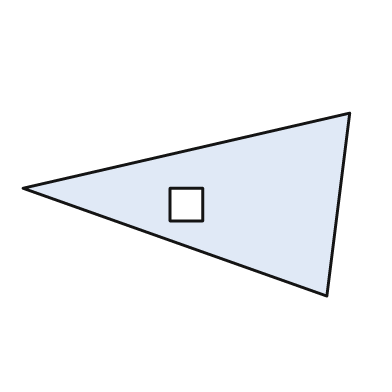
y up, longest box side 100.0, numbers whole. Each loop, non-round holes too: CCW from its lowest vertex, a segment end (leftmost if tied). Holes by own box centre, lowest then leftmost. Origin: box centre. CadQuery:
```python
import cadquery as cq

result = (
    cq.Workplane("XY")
    .moveTo(43.0, -28.0)
    .lineTo(50.0, 28.0)
    .lineTo(-50.0, 5.0)
    .close()
    .moveTo(-5.0, -5.0)
    .lineTo(5.0, -5.0)
    .lineTo(5.0, 5.0)
    .lineTo(-5.0, 5.0)
    .close()
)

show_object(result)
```